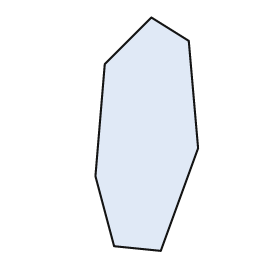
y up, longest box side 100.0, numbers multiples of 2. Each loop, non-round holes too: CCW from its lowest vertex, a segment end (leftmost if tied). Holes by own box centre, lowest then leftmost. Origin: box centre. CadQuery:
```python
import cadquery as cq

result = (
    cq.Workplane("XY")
    .moveTo(6.0, -50.0)
    .lineTo(22.0, -6.0)
    .lineTo(18.0, 40.0)
    .lineTo(2.0, 50.0)
    .lineTo(-18.0, 30.0)
    .lineTo(-22.0, -18.0)
    .lineTo(-14.0, -48.0)
    .close()
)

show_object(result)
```